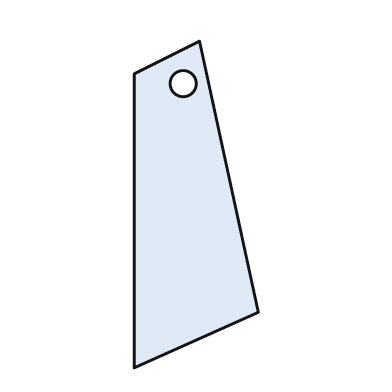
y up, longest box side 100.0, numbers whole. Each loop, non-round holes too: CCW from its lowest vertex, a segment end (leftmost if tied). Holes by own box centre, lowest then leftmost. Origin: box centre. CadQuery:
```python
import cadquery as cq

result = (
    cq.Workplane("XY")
    .moveTo(-19.0, -50.0)
    .lineTo(19.0, -33.0)
    .lineTo(1.0, 50.0)
    .lineTo(-19.0, 40.0)
    .close()
    .moveTo(-4.0, 37.0)
    .circle(4.0)
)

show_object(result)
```